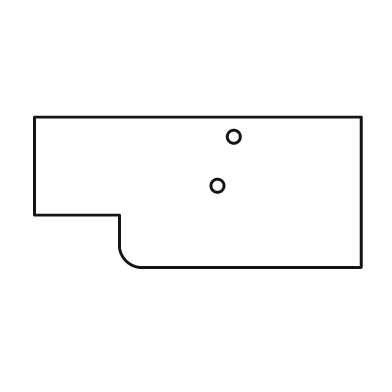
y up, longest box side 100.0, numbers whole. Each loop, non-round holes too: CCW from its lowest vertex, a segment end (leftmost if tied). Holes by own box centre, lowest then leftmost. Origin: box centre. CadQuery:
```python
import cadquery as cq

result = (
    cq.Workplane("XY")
    .moveTo(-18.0, -23.0)
    .lineTo(50.0, -23.0)
    .lineTo(50.0, 23.0)
    .lineTo(-50.0, 23.0)
    .lineTo(-50.0, -7.0)
    .lineTo(-24.0, -7.0)
    .lineTo(-24.0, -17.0)
    .threePointArc((-22.0, -21.0), (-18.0, -23.0))
    .close()
    .moveTo(6.0, 2.0)
    .circle(2.0)
    .moveTo(11.0, 17.0)
    .circle(2.0)
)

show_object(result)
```